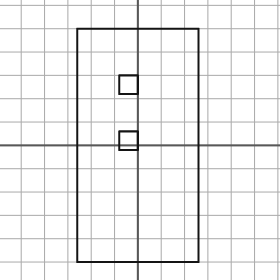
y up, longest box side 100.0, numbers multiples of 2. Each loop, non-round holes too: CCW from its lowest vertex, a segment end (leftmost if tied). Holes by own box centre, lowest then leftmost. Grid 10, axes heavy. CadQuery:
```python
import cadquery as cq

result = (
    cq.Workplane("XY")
    .moveTo(-26.0, -50.0)
    .lineTo(26.0, -50.0)
    .lineTo(26.0, 50.0)
    .lineTo(-26.0, 50.0)
    .close()
    .moveTo(-8.0, -2.0)
    .lineTo(0.0, -2.0)
    .lineTo(0.0, 6.0)
    .lineTo(-8.0, 6.0)
    .close()
    .moveTo(-8.0, 22.0)
    .lineTo(0.0, 22.0)
    .lineTo(0.0, 30.0)
    .lineTo(-8.0, 30.0)
    .close()
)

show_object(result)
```